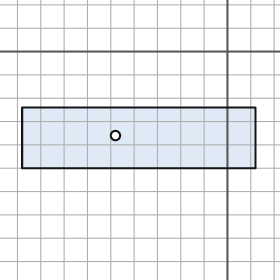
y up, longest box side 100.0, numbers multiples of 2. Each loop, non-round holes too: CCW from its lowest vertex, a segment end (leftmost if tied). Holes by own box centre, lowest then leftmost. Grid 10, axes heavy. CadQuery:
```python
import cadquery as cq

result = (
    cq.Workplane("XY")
    .moveTo(-88.0, -50.0)
    .lineTo(12.0, -50.0)
    .lineTo(12.0, -24.0)
    .lineTo(-88.0, -24.0)
    .close()
    .moveTo(-48.0, -36.0)
    .circle(2.0)
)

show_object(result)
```